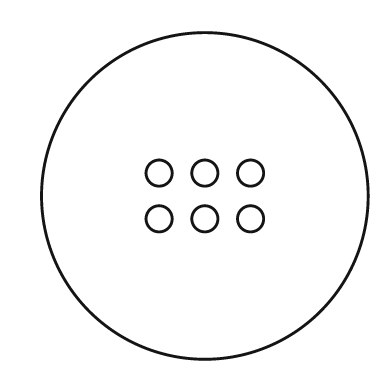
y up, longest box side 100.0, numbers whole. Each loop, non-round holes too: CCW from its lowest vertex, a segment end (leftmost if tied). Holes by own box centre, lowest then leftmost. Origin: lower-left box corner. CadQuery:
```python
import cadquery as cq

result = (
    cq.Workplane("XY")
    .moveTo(50.0, 50.0)
    .circle(50.0)
    .moveTo(36.0, 43.0)
    .circle(4.0)
    .moveTo(50.0, 43.0)
    .circle(4.0)
    .moveTo(64.0, 43.0)
    .circle(4.0)
    .moveTo(36.0, 57.0)
    .circle(4.0)
    .moveTo(50.0, 57.0)
    .circle(4.0)
    .moveTo(64.0, 57.0)
    .circle(4.0)
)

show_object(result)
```